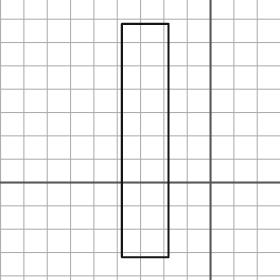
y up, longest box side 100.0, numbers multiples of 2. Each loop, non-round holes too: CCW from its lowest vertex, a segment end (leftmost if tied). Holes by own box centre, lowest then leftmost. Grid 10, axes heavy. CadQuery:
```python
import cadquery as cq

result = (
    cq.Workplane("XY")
    .moveTo(-38.0, -32.0)
    .lineTo(-18.0, -32.0)
    .lineTo(-18.0, 68.0)
    .lineTo(-38.0, 68.0)
    .close()
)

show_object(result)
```